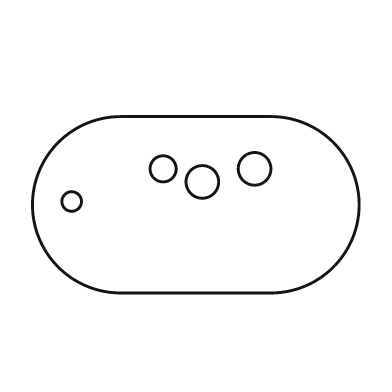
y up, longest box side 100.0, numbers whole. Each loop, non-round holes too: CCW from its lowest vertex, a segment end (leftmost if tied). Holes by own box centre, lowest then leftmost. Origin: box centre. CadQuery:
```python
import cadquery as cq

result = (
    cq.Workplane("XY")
    .moveTo(-23.0, -27.0)
    .lineTo(23.0, -27.0)
    .threePointArc((50.0, 0.0), (23.0, 27.0))
    .lineTo(-23.0, 27.0)
    .threePointArc((-50.0, 0.0), (-23.0, -27.0))
    .close()
    .moveTo(-38.0, 1.0)
    .circle(3.0)
    .moveTo(2.0, 7.0)
    .circle(5.0)
    .moveTo(-10.0, 11.0)
    .circle(4.0)
    .moveTo(18.0, 11.0)
    .circle(5.0)
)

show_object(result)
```